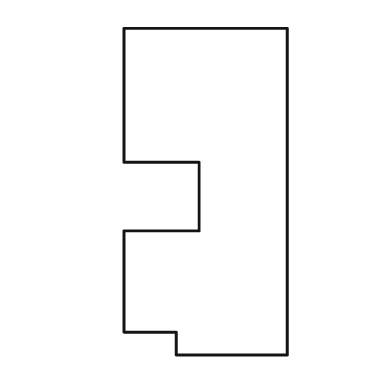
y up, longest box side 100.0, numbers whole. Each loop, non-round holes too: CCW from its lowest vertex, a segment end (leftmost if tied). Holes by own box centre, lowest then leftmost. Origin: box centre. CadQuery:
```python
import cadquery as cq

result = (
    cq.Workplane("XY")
    .moveTo(-9.0, -50.0)
    .lineTo(25.0, -50.0)
    .lineTo(25.0, 50.0)
    .lineTo(-25.0, 50.0)
    .lineTo(-25.0, 9.0)
    .lineTo(-2.0, 9.0)
    .lineTo(-2.0, -12.0)
    .lineTo(-25.0, -12.0)
    .lineTo(-25.0, -43.0)
    .lineTo(-9.0, -43.0)
    .close()
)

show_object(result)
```